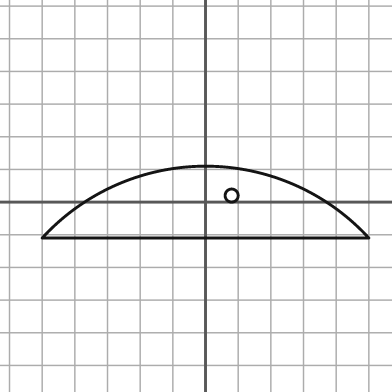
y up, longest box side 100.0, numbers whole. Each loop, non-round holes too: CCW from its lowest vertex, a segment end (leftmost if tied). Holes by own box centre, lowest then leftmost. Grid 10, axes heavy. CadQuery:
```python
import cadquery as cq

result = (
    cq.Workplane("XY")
    .moveTo(-50.0, -11.0)
    .lineTo(50.0, -11.0)
    .threePointArc((0.0, 11.0), (-50.0, -11.0))
    .close()
    .moveTo(8.0, 2.0)
    .circle(2.0)
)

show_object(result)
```